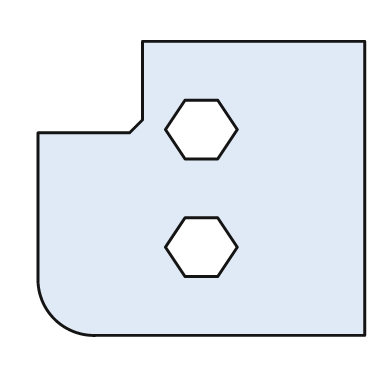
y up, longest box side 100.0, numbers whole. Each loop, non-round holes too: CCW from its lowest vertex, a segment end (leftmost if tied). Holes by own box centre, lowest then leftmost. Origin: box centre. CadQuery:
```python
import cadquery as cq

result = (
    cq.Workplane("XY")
    .moveTo(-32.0, -45.0)
    .lineTo(50.0, -45.0)
    .lineTo(50.0, 45.0)
    .lineTo(-18.0, 45.0)
    .lineTo(-18.0, 21.0)
    .lineTo(-22.0, 17.0)
    .lineTo(-50.0, 17.0)
    .lineTo(-50.0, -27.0)
    .threePointArc((-45.0, -40.0), (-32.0, -45.0))
    .close()
    .moveTo(-5.0, -27.0)
    .lineTo(5.0, -27.0)
    .lineTo(11.0, -18.0)
    .lineTo(5.0, -9.0)
    .lineTo(-5.0, -9.0)
    .lineTo(-11.0, -18.0)
    .close()
    .moveTo(-5.0, 9.0)
    .lineTo(5.0, 9.0)
    .lineTo(11.0, 18.0)
    .lineTo(5.0, 27.0)
    .lineTo(-5.0, 27.0)
    .lineTo(-11.0, 18.0)
    .close()
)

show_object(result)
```